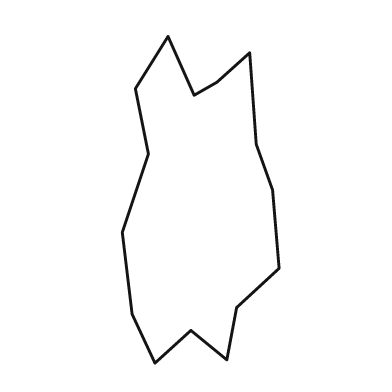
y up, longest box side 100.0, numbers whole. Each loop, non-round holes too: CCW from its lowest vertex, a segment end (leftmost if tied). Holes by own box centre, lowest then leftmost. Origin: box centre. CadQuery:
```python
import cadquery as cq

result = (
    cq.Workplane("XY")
    .moveTo(-14.0, -50.0)
    .lineTo(-3.0, -40.0)
    .lineTo(8.0, -49.0)
    .lineTo(11.0, -33.0)
    .lineTo(24.0, -21.0)
    .lineTo(22.0, 3.0)
    .lineTo(17.0, 17.0)
    .lineTo(15.0, 45.0)
    .lineTo(5.0, 36.0)
    .lineTo(-2.0, 32.0)
    .lineTo(-10.0, 50.0)
    .lineTo(-20.0, 34.0)
    .lineTo(-16.0, 14.0)
    .lineTo(-24.0, -10.0)
    .lineTo(-21.0, -35.0)
    .close()
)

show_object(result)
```